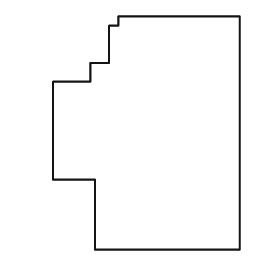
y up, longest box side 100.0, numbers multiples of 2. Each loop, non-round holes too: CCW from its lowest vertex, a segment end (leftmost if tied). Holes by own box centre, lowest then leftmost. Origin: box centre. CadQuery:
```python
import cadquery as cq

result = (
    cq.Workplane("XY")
    .moveTo(-22.0, -50.0)
    .lineTo(40.0, -50.0)
    .lineTo(40.0, 50.0)
    .lineTo(-12.0, 50.0)
    .lineTo(-12.0, 46.0)
    .lineTo(-16.0, 46.0)
    .lineTo(-16.0, 30.0)
    .lineTo(-24.0, 30.0)
    .lineTo(-24.0, 22.0)
    .lineTo(-40.0, 22.0)
    .lineTo(-40.0, -20.0)
    .lineTo(-22.0, -20.0)
    .close()
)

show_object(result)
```